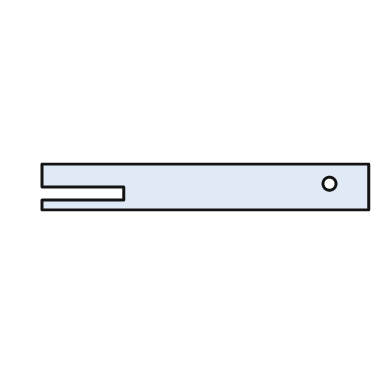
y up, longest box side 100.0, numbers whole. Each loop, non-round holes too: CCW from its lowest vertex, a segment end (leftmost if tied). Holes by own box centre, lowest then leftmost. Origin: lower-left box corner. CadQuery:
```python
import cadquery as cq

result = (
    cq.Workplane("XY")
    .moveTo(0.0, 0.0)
    .lineTo(100.0, 0.0)
    .lineTo(100.0, 14.0)
    .lineTo(0.0, 14.0)
    .lineTo(0.0, 7.0)
    .lineTo(25.0, 7.0)
    .lineTo(25.0, 3.0)
    .lineTo(0.0, 3.0)
    .close()
    .moveTo(88.0, 8.0)
    .circle(2.0)
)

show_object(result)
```